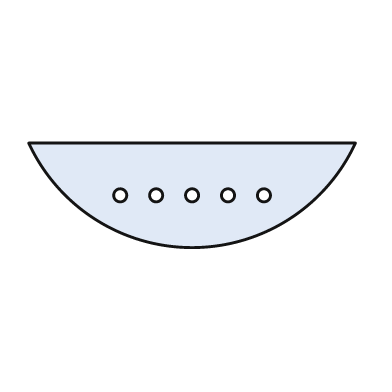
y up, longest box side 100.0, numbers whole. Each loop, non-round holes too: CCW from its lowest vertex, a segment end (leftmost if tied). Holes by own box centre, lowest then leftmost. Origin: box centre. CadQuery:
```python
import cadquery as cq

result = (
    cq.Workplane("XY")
    .moveTo(-50.0, 16.0)
    .threePointArc((0.0, -16.0), (50.0, 16.0))
    .close()
    .moveTo(-22.0, 0.0)
    .circle(2.0)
    .moveTo(-11.0, 0.0)
    .circle(2.0)
    .moveTo(0.0, 0.0)
    .circle(2.0)
    .moveTo(11.0, 0.0)
    .circle(2.0)
    .moveTo(22.0, 0.0)
    .circle(2.0)
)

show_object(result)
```